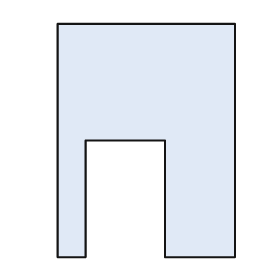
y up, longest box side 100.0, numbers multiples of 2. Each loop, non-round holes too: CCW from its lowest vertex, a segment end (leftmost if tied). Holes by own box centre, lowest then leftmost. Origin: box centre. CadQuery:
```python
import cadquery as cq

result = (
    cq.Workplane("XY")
    .moveTo(-38.0, -50.0)
    .lineTo(-26.0, -50.0)
    .lineTo(-26.0, 0.0)
    .lineTo(8.0, 0.0)
    .lineTo(8.0, -50.0)
    .lineTo(38.0, -50.0)
    .lineTo(38.0, 50.0)
    .lineTo(-38.0, 50.0)
    .close()
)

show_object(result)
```